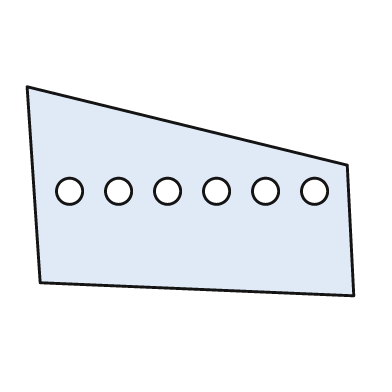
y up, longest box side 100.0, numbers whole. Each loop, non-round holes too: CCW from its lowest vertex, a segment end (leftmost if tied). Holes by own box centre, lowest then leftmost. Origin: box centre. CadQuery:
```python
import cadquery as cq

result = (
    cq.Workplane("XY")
    .moveTo(50.0, -32.0)
    .lineTo(48.0, 8.0)
    .lineTo(-50.0, 32.0)
    .lineTo(-46.0, -28.0)
    .close()
    .moveTo(-37.0, 0.0)
    .circle(4.0)
    .moveTo(-22.0, 0.0)
    .circle(4.0)
    .moveTo(-7.0, 0.0)
    .circle(4.0)
    .moveTo(8.0, 0.0)
    .circle(4.0)
    .moveTo(23.0, 0.0)
    .circle(4.0)
    .moveTo(38.0, 0.0)
    .circle(4.0)
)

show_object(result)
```